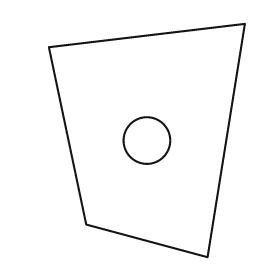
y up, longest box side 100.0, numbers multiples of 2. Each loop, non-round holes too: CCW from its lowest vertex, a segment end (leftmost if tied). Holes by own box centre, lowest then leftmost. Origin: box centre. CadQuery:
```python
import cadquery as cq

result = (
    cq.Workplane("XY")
    .moveTo(26.0, -50.0)
    .lineTo(42.0, 50.0)
    .lineTo(-42.0, 40.0)
    .lineTo(-26.0, -36.0)
    .close()
    .moveTo(0.0, 0.0)
    .circle(10.0)
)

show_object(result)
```